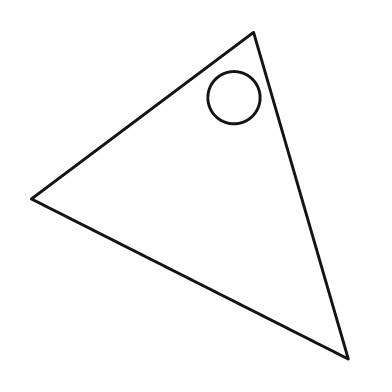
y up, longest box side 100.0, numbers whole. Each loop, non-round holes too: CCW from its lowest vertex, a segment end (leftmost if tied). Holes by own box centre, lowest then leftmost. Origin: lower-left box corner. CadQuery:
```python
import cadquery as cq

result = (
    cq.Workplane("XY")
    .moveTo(97.0, 0.0)
    .lineTo(68.0, 100.0)
    .lineTo(0.0, 49.0)
    .close()
    .moveTo(62.0, 80.0)
    .circle(8.0)
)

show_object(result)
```